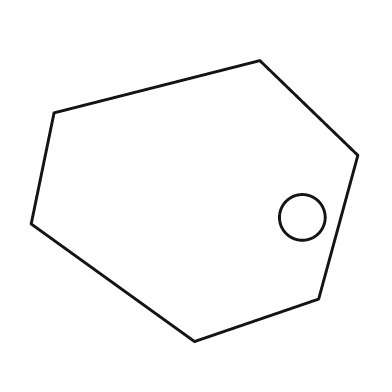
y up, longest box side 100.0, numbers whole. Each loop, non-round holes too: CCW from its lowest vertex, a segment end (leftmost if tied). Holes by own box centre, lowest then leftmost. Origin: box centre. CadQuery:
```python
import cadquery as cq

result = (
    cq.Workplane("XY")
    .moveTo(0.0, -43.0)
    .lineTo(38.0, -30.0)
    .lineTo(50.0, 14.0)
    .lineTo(20.0, 43.0)
    .lineTo(-43.0, 27.0)
    .lineTo(-50.0, -7.0)
    .close()
    .moveTo(33.0, -5.0)
    .circle(7.0)
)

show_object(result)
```